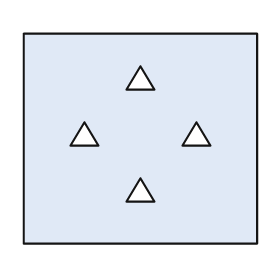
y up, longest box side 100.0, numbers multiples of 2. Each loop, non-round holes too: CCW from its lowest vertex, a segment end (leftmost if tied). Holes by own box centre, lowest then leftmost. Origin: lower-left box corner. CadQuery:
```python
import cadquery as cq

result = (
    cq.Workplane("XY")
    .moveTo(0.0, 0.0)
    .lineTo(100.0, 0.0)
    .lineTo(100.0, 90.0)
    .lineTo(0.0, 90.0)
    .close()
    .moveTo(44.0, 18.0)
    .lineTo(56.0, 18.0)
    .lineTo(50.0, 28.0)
    .close()
    .moveTo(20.0, 42.0)
    .lineTo(32.0, 42.0)
    .lineTo(26.0, 52.0)
    .close()
    .moveTo(68.0, 42.0)
    .lineTo(80.0, 42.0)
    .lineTo(74.0, 52.0)
    .close()
    .moveTo(44.0, 66.0)
    .lineTo(56.0, 66.0)
    .lineTo(50.0, 76.0)
    .close()
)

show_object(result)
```